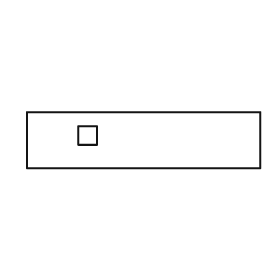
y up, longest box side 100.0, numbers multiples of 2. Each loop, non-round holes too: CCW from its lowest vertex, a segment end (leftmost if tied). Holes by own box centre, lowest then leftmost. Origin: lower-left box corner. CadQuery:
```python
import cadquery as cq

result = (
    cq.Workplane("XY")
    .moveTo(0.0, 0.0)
    .lineTo(100.0, 0.0)
    .lineTo(100.0, 24.0)
    .lineTo(0.0, 24.0)
    .close()
    .moveTo(22.0, 10.0)
    .lineTo(30.0, 10.0)
    .lineTo(30.0, 18.0)
    .lineTo(22.0, 18.0)
    .close()
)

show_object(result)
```